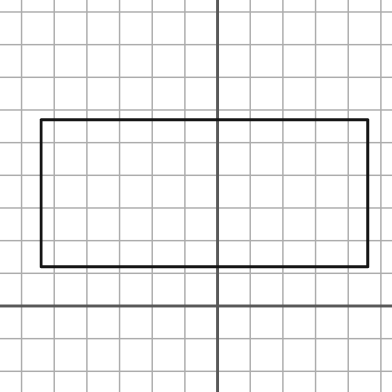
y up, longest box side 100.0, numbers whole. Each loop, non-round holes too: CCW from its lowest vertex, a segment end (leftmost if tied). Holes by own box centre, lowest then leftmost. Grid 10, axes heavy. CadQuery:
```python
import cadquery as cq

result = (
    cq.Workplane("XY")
    .moveTo(-54.0, 12.0)
    .lineTo(46.0, 12.0)
    .lineTo(46.0, 57.0)
    .lineTo(-54.0, 57.0)
    .close()
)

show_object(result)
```